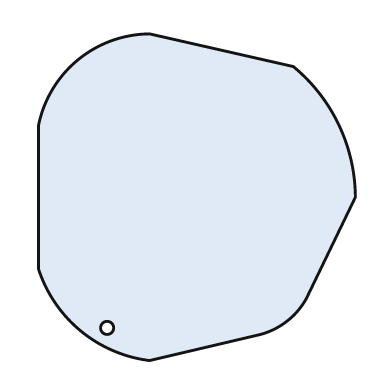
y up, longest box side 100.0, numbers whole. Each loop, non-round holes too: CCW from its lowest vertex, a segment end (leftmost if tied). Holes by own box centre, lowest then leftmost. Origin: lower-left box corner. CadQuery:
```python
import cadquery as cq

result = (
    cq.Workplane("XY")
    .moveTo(34.0, 0.0)
    .lineTo(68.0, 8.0)
    .threePointArc((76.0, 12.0), (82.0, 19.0))
    .lineTo(97.0, 50.0)
    .threePointArc((92.0, 72.0), (78.0, 90.0))
    .lineTo(34.0, 100.0)
    .threePointArc((12.0, 92.0), (0.0, 72.0))
    .lineTo(0.0, 28.0)
    .threePointArc((13.0, 9.0), (34.0, 0.0))
    .close()
    .moveTo(21.0, 10.0)
    .circle(2.0)
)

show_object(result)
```